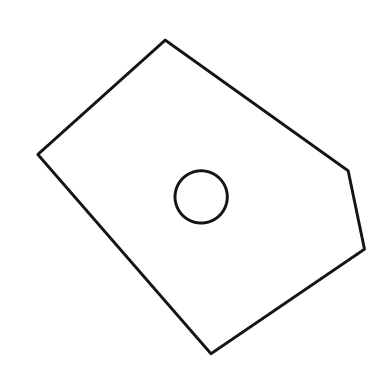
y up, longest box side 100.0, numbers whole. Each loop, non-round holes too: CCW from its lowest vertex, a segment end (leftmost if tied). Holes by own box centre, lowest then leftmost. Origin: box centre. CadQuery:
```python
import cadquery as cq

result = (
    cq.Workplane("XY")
    .moveTo(3.0, -48.0)
    .lineTo(50.0, -16.0)
    .lineTo(45.0, 8.0)
    .lineTo(-11.0, 48.0)
    .lineTo(-50.0, 13.0)
    .close()
    .moveTo(0.0, 0.0)
    .circle(8.0)
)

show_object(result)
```